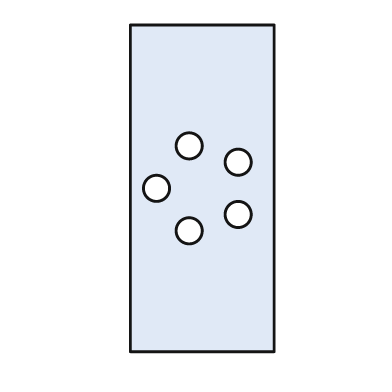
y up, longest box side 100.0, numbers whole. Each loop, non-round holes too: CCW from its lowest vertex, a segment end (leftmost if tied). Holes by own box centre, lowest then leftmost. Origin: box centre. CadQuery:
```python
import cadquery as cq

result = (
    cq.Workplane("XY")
    .moveTo(-22.0, -50.0)
    .lineTo(22.0, -50.0)
    .lineTo(22.0, 50.0)
    .lineTo(-22.0, 50.0)
    .close()
    .moveTo(-4.0, -13.0)
    .circle(4.0)
    .moveTo(11.0, -8.0)
    .circle(4.0)
    .moveTo(-14.0, 0.0)
    .circle(4.0)
    .moveTo(11.0, 8.0)
    .circle(4.0)
    .moveTo(-4.0, 13.0)
    .circle(4.0)
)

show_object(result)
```